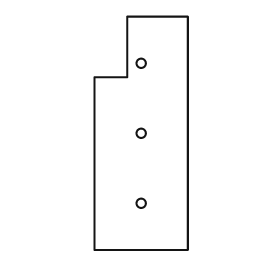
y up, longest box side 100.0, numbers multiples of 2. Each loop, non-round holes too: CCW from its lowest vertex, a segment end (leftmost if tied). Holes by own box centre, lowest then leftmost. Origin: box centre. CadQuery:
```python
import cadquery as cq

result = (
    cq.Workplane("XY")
    .moveTo(-20.0, -50.0)
    .lineTo(20.0, -50.0)
    .lineTo(20.0, 50.0)
    .lineTo(-6.0, 50.0)
    .lineTo(-6.0, 24.0)
    .lineTo(-20.0, 24.0)
    .close()
    .moveTo(0.0, -30.0)
    .circle(2.0)
    .moveTo(0.0, 0.0)
    .circle(2.0)
    .moveTo(0.0, 30.0)
    .circle(2.0)
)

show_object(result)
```